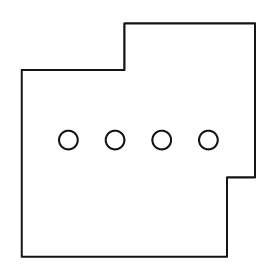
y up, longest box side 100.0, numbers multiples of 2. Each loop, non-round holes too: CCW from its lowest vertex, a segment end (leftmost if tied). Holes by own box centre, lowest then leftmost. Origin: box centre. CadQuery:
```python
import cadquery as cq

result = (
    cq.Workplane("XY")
    .moveTo(-50.0, -50.0)
    .lineTo(38.0, -50.0)
    .lineTo(38.0, -16.0)
    .lineTo(50.0, -16.0)
    .lineTo(50.0, 50.0)
    .lineTo(-6.0, 50.0)
    .lineTo(-6.0, 30.0)
    .lineTo(-50.0, 30.0)
    .close()
    .moveTo(-30.0, 0.0)
    .circle(4.0)
    .moveTo(-10.0, 0.0)
    .circle(4.0)
    .moveTo(10.0, 0.0)
    .circle(4.0)
    .moveTo(30.0, 0.0)
    .circle(4.0)
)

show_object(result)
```